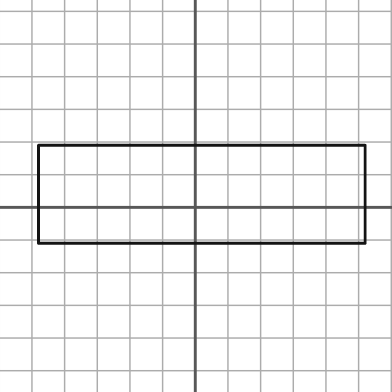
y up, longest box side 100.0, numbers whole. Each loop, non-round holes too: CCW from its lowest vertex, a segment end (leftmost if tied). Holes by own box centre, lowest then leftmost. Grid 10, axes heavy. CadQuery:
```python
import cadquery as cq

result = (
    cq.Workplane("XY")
    .moveTo(-48.0, -11.0)
    .lineTo(52.0, -11.0)
    .lineTo(52.0, 19.0)
    .lineTo(-48.0, 19.0)
    .close()
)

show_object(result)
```